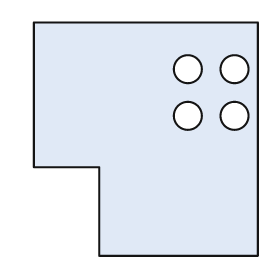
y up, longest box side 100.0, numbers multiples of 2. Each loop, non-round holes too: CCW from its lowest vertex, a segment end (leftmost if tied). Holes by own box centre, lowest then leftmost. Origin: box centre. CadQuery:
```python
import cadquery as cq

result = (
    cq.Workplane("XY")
    .moveTo(-20.0, -50.0)
    .lineTo(48.0, -50.0)
    .lineTo(48.0, 50.0)
    .lineTo(-48.0, 50.0)
    .lineTo(-48.0, -12.0)
    .lineTo(-20.0, -12.0)
    .close()
    .moveTo(18.0, 10.0)
    .circle(6.0)
    .moveTo(38.0, 10.0)
    .circle(6.0)
    .moveTo(18.0, 30.0)
    .circle(6.0)
    .moveTo(38.0, 30.0)
    .circle(6.0)
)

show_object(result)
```